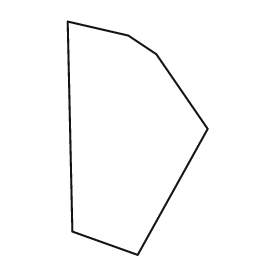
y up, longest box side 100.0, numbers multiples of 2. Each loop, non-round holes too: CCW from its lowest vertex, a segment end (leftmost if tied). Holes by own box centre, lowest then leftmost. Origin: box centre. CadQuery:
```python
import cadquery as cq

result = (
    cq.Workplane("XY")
    .moveTo(0.0, -50.0)
    .lineTo(30.0, 4.0)
    .lineTo(8.0, 36.0)
    .lineTo(-4.0, 44.0)
    .lineTo(-30.0, 50.0)
    .lineTo(-28.0, -40.0)
    .close()
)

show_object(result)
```